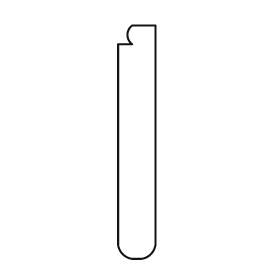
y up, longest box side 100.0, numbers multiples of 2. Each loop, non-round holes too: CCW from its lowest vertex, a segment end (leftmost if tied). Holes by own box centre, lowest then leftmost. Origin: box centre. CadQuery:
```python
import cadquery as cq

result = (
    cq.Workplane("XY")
    .moveTo(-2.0, -50.0)
    .lineTo(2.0, -50.0)
    .threePointArc((6.0, -48.0), (8.0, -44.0))
    .lineTo(8.0, 50.0)
    .lineTo(-2.0, 50.0)
    .threePointArc((-4.0, 46.0), (-2.0, 42.0))
    .lineTo(-8.0, 42.0)
    .lineTo(-8.0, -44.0)
    .threePointArc((-6.0, -48.0), (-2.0, -50.0))
    .close()
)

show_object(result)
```